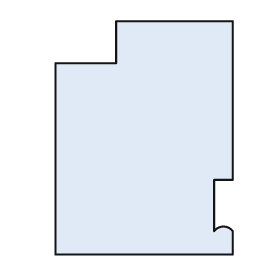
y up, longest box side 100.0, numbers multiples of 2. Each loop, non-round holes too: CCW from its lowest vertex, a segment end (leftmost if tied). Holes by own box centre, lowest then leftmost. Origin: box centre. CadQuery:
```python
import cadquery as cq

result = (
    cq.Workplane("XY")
    .moveTo(-38.0, -50.0)
    .lineTo(38.0, -50.0)
    .lineTo(38.0, -40.0)
    .threePointArc((34.0, -38.0), (30.0, -40.0))
    .lineTo(30.0, -18.0)
    .lineTo(38.0, -18.0)
    .lineTo(38.0, 50.0)
    .lineTo(-12.0, 50.0)
    .lineTo(-12.0, 32.0)
    .lineTo(-38.0, 32.0)
    .close()
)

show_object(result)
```